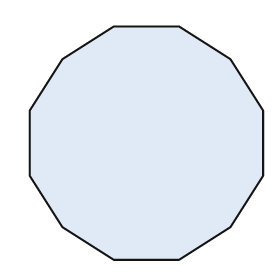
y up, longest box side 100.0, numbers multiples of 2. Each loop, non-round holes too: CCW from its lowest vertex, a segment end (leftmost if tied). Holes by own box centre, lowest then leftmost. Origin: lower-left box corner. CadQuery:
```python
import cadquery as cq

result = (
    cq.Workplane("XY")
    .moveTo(36.0, 0.0)
    .lineTo(64.0, 0.0)
    .lineTo(86.0, 14.0)
    .lineTo(100.0, 36.0)
    .lineTo(100.0, 64.0)
    .lineTo(86.0, 86.0)
    .lineTo(64.0, 100.0)
    .lineTo(36.0, 100.0)
    .lineTo(14.0, 86.0)
    .lineTo(0.0, 64.0)
    .lineTo(0.0, 36.0)
    .lineTo(14.0, 14.0)
    .close()
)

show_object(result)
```